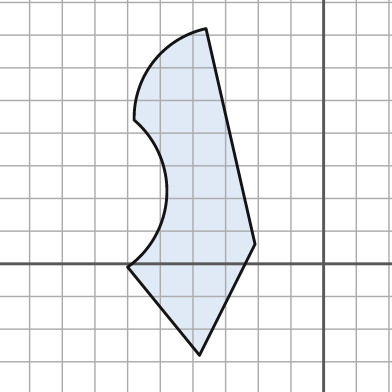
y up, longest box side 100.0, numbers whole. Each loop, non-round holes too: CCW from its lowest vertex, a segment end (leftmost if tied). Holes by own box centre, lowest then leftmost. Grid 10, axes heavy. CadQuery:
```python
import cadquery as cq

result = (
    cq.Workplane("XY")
    .moveTo(-38.0, -28.0)
    .lineTo(-21.0, 6.0)
    .lineTo(-36.0, 72.0)
    .threePointArc((-52.0, 62.0), (-58.0, 44.0))
    .threePointArc((-48.0, 21.0), (-60.0, -1.0))
    .close()
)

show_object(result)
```